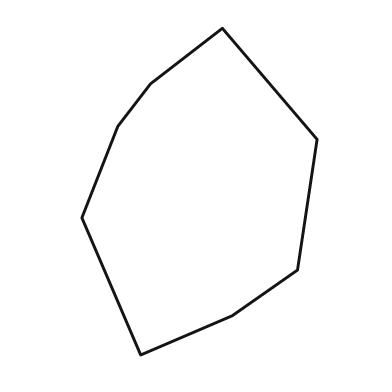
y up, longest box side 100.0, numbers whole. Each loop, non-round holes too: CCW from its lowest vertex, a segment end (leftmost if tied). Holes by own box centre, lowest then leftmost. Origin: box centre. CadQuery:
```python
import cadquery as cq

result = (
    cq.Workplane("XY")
    .moveTo(-18.0, -50.0)
    .lineTo(10.0, -38.0)
    .lineTo(30.0, -24.0)
    .lineTo(36.0, 16.0)
    .lineTo(7.0, 50.0)
    .lineTo(-15.0, 33.0)
    .lineTo(-25.0, 20.0)
    .lineTo(-36.0, -8.0)
    .close()
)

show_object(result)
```